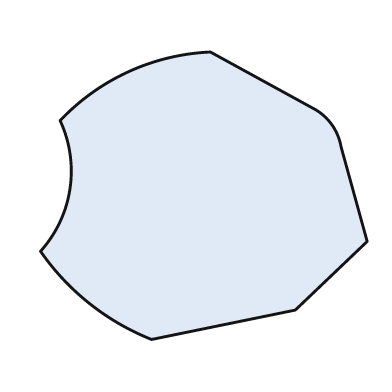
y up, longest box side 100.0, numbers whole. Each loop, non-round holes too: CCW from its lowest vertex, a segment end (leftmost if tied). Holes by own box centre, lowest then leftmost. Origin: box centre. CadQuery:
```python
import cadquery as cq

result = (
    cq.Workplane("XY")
    .moveTo(-16.0, -44.0)
    .lineTo(28.0, -35.0)
    .lineTo(50.0, -14.0)
    .lineTo(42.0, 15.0)
    .threePointArc((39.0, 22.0), (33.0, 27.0))
    .lineTo(2.0, 44.0)
    .threePointArc((-23.0, 38.0), (-44.0, 23.0))
    .threePointArc((-41.0, 2.0), (-50.0, -17.0))
    .threePointArc((-35.0, -33.0), (-16.0, -44.0))
    .close()
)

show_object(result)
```